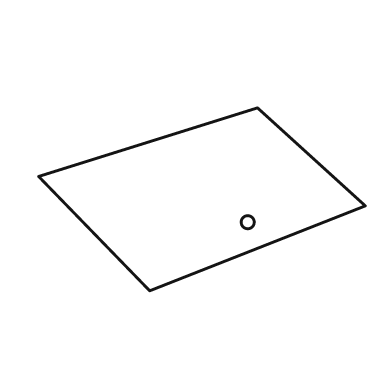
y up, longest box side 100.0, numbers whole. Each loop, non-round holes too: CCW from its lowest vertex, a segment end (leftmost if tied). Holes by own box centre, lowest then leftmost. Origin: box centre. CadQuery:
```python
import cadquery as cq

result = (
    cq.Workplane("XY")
    .moveTo(-16.0, -28.0)
    .lineTo(50.0, -2.0)
    .lineTo(17.0, 28.0)
    .lineTo(-50.0, 7.0)
    .close()
    .moveTo(14.0, -7.0)
    .circle(2.0)
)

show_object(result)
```